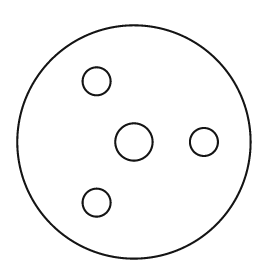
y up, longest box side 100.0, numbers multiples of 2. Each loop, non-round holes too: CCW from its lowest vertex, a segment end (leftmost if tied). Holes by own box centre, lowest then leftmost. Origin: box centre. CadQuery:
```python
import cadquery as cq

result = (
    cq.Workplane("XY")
    .moveTo(0.0, 0.0)
    .circle(50.0)
    .moveTo(-16.0, -26.0)
    .circle(6.0)
    .moveTo(0.0, 0.0)
    .circle(8.0)
    .moveTo(30.0, 0.0)
    .circle(6.0)
    .moveTo(-16.0, 26.0)
    .circle(6.0)
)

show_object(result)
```